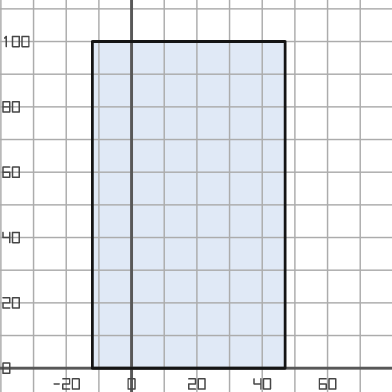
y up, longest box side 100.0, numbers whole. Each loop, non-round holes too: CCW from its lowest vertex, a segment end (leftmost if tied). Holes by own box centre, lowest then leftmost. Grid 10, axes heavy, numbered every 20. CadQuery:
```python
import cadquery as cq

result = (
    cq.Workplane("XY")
    .moveTo(-12.0, 0.0)
    .lineTo(47.0, 0.0)
    .lineTo(47.0, 100.0)
    .lineTo(-12.0, 100.0)
    .close()
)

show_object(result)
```